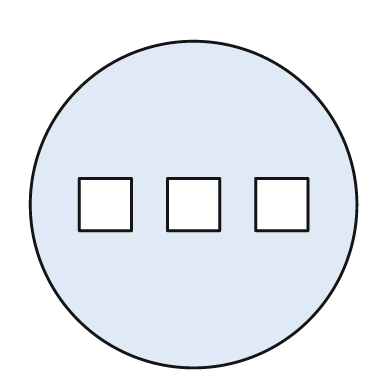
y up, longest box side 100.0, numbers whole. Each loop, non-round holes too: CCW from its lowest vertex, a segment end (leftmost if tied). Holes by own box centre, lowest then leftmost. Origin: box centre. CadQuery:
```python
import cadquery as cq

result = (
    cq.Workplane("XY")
    .moveTo(0.0, 0.0)
    .circle(50.0)
    .moveTo(-35.0, -8.0)
    .lineTo(-19.0, -8.0)
    .lineTo(-19.0, 8.0)
    .lineTo(-35.0, 8.0)
    .close()
    .moveTo(-8.0, -8.0)
    .lineTo(8.0, -8.0)
    .lineTo(8.0, 8.0)
    .lineTo(-8.0, 8.0)
    .close()
    .moveTo(19.0, -8.0)
    .lineTo(35.0, -8.0)
    .lineTo(35.0, 8.0)
    .lineTo(19.0, 8.0)
    .close()
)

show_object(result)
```